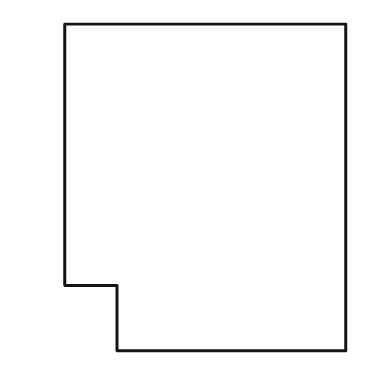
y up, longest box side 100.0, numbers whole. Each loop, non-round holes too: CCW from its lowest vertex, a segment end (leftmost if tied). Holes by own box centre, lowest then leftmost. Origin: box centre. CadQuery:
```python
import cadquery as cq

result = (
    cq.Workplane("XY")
    .moveTo(-27.0, -50.0)
    .lineTo(43.0, -50.0)
    .lineTo(43.0, 50.0)
    .lineTo(-43.0, 50.0)
    .lineTo(-43.0, -30.0)
    .lineTo(-27.0, -30.0)
    .close()
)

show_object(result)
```